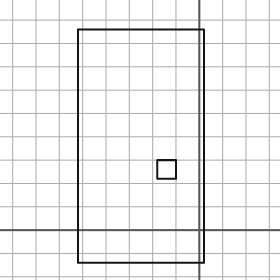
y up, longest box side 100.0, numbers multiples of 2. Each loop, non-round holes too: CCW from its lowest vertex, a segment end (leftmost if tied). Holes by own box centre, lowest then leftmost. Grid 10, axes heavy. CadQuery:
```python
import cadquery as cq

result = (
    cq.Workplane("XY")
    .moveTo(-52.0, -14.0)
    .lineTo(2.0, -14.0)
    .lineTo(2.0, 86.0)
    .lineTo(-52.0, 86.0)
    .close()
    .moveTo(-18.0, 22.0)
    .lineTo(-10.0, 22.0)
    .lineTo(-10.0, 30.0)
    .lineTo(-18.0, 30.0)
    .close()
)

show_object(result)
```